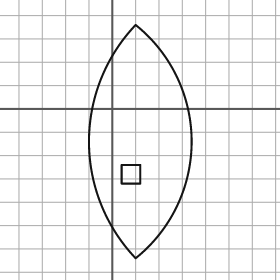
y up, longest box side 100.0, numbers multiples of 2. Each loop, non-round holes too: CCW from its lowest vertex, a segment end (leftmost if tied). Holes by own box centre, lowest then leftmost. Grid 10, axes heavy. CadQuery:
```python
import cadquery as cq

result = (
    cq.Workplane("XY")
    .moveTo(10.0, -64.0)
    .threePointArc((34.0, -14.0), (10.0, 36.0))
    .threePointArc((-10.0, -14.0), (10.0, -64.0))
    .close()
    .moveTo(4.0, -32.0)
    .lineTo(12.0, -32.0)
    .lineTo(12.0, -24.0)
    .lineTo(4.0, -24.0)
    .close()
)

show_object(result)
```